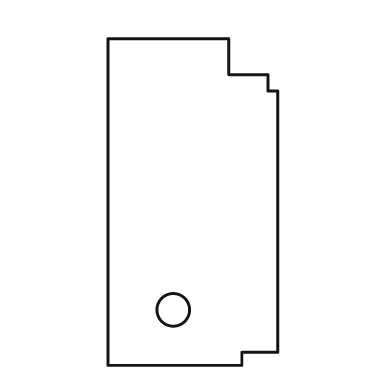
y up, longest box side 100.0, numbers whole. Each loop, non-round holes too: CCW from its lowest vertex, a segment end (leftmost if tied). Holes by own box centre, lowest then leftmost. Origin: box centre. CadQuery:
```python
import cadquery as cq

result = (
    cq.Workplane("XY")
    .moveTo(-26.0, -50.0)
    .lineTo(15.0, -50.0)
    .lineTo(15.0, -46.0)
    .lineTo(26.0, -46.0)
    .lineTo(26.0, 34.0)
    .lineTo(23.0, 34.0)
    .lineTo(23.0, 39.0)
    .lineTo(11.0, 39.0)
    .lineTo(11.0, 50.0)
    .lineTo(-26.0, 50.0)
    .close()
    .moveTo(-6.0, -33.0)
    .circle(5.0)
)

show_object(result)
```